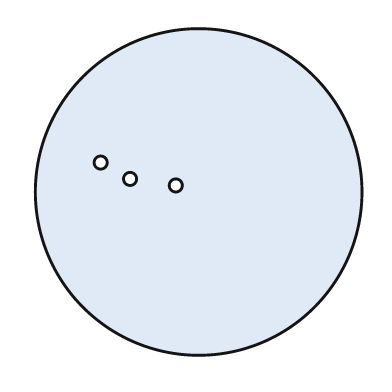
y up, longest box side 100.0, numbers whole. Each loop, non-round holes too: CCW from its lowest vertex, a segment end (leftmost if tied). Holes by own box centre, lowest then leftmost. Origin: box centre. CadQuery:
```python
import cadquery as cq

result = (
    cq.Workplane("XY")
    .moveTo(0.0, 0.0)
    .circle(50.0)
    .moveTo(-7.0, 2.0)
    .circle(2.0)
    .moveTo(-21.0, 4.0)
    .circle(2.0)
    .moveTo(-30.0, 9.0)
    .circle(2.0)
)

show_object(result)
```